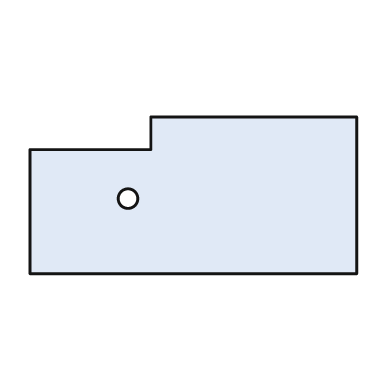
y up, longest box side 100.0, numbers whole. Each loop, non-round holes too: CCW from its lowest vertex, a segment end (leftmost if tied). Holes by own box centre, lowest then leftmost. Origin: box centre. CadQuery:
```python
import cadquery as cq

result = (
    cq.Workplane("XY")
    .moveTo(-50.0, -24.0)
    .lineTo(50.0, -24.0)
    .lineTo(50.0, 24.0)
    .lineTo(-13.0, 24.0)
    .lineTo(-13.0, 14.0)
    .lineTo(-50.0, 14.0)
    .close()
    .moveTo(-20.0, -1.0)
    .circle(3.0)
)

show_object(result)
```